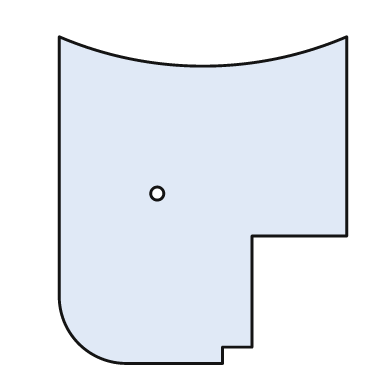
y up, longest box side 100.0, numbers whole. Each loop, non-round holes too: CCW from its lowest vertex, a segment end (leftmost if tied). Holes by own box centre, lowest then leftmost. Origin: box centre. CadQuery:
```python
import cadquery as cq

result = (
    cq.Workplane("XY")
    .moveTo(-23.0, -50.0)
    .lineTo(6.0, -50.0)
    .lineTo(6.0, -45.0)
    .lineTo(15.0, -45.0)
    .lineTo(15.0, -11.0)
    .lineTo(44.0, -11.0)
    .lineTo(44.0, 50.0)
    .threePointArc((0.0, 41.0), (-44.0, 50.0))
    .lineTo(-44.0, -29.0)
    .threePointArc((-38.0, -44.0), (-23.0, -50.0))
    .close()
    .moveTo(-14.0, 2.0)
    .circle(2.0)
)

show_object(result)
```